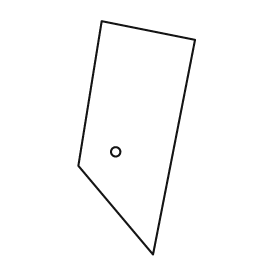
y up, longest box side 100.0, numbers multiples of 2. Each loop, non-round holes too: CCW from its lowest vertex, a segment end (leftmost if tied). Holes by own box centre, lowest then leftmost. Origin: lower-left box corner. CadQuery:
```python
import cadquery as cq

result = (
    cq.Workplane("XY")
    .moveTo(32.0, 0.0)
    .lineTo(50.0, 92.0)
    .lineTo(10.0, 100.0)
    .lineTo(0.0, 38.0)
    .close()
    .moveTo(16.0, 44.0)
    .circle(2.0)
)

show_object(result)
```